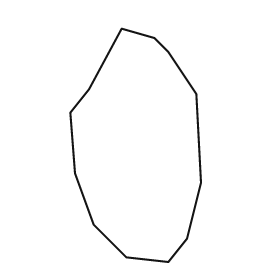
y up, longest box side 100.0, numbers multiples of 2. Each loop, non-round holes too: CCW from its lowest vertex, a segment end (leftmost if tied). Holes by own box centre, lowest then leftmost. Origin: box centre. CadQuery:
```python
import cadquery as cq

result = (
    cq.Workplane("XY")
    .moveTo(14.0, -50.0)
    .lineTo(22.0, -40.0)
    .lineTo(28.0, -16.0)
    .lineTo(26.0, 22.0)
    .lineTo(14.0, 40.0)
    .lineTo(8.0, 46.0)
    .lineTo(-6.0, 50.0)
    .lineTo(-20.0, 24.0)
    .lineTo(-28.0, 14.0)
    .lineTo(-26.0, -12.0)
    .lineTo(-18.0, -34.0)
    .lineTo(-4.0, -48.0)
    .close()
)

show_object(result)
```